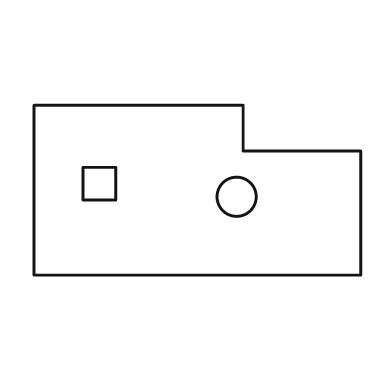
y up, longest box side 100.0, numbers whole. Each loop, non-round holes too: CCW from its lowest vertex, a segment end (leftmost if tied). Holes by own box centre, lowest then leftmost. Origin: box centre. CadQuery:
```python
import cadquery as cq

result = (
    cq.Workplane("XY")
    .moveTo(-50.0, -26.0)
    .lineTo(50.0, -26.0)
    .lineTo(50.0, 12.0)
    .lineTo(14.0, 12.0)
    .lineTo(14.0, 26.0)
    .lineTo(-50.0, 26.0)
    .close()
    .moveTo(12.0, -2.0)
    .circle(6.0)
    .moveTo(-35.0, -3.0)
    .lineTo(-25.0, -3.0)
    .lineTo(-25.0, 7.0)
    .lineTo(-35.0, 7.0)
    .close()
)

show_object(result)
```